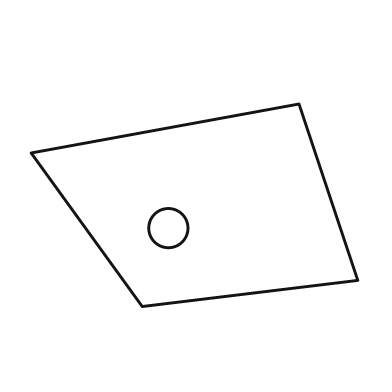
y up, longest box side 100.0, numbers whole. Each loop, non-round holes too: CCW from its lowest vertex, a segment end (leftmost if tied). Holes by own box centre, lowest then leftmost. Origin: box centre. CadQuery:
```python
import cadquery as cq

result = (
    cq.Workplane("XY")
    .moveTo(-16.0, -31.0)
    .lineTo(50.0, -23.0)
    .lineTo(32.0, 31.0)
    .lineTo(-50.0, 16.0)
    .close()
    .moveTo(-8.0, -7.0)
    .circle(6.0)
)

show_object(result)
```